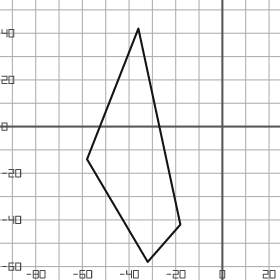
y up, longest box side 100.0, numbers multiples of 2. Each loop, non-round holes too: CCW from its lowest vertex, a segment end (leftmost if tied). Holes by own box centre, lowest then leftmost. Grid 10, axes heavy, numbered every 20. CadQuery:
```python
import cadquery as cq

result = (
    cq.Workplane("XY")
    .moveTo(-32.0, -58.0)
    .lineTo(-18.0, -42.0)
    .lineTo(-36.0, 42.0)
    .lineTo(-58.0, -14.0)
    .close()
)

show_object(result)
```